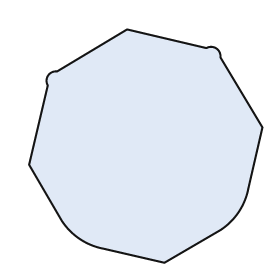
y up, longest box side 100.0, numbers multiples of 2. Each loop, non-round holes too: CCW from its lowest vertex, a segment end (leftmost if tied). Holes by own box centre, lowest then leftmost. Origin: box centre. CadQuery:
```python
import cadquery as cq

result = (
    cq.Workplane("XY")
    .moveTo(8.0, -50.0)
    .lineTo(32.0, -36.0)
    .threePointArc((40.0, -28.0), (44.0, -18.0))
    .lineTo(50.0, 8.0)
    .lineTo(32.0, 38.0)
    .threePointArc((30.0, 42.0), (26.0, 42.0))
    .lineTo(-8.0, 50.0)
    .lineTo(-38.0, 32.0)
    .threePointArc((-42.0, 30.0), (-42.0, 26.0))
    .lineTo(-50.0, -8.0)
    .lineTo(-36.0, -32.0)
    .threePointArc((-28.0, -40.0), (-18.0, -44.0))
    .close()
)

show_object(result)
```